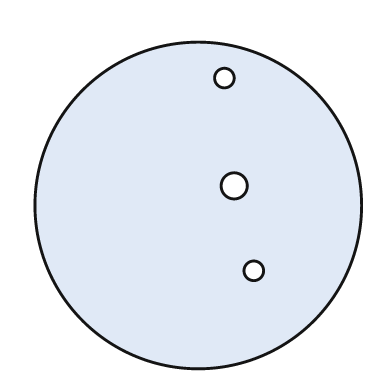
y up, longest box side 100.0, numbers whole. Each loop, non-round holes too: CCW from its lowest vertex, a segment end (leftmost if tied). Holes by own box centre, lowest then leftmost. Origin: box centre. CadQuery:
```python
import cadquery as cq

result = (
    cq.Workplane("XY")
    .moveTo(0.0, 0.0)
    .circle(50.0)
    .moveTo(17.0, -20.0)
    .circle(3.0)
    .moveTo(11.0, 6.0)
    .circle(4.0)
    .moveTo(8.0, 39.0)
    .circle(3.0)
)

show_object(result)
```